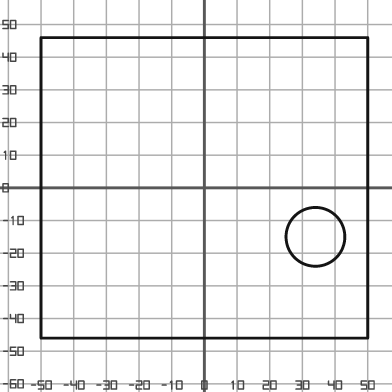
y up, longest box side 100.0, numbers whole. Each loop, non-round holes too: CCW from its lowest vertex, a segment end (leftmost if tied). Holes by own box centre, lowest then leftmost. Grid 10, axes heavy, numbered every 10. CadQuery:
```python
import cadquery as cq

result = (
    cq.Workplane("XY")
    .moveTo(-50.0, -46.0)
    .lineTo(50.0, -46.0)
    .lineTo(50.0, 46.0)
    .lineTo(-50.0, 46.0)
    .close()
    .moveTo(34.0, -15.0)
    .circle(9.0)
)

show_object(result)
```